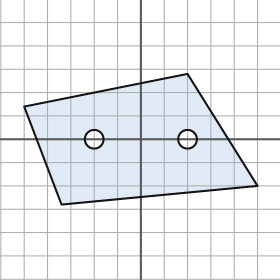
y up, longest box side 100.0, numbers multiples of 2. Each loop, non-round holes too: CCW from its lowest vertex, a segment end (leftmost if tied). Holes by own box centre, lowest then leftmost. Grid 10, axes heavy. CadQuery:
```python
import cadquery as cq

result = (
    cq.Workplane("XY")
    .moveTo(-34.0, -28.0)
    .lineTo(50.0, -20.0)
    .lineTo(20.0, 28.0)
    .lineTo(-50.0, 14.0)
    .close()
    .moveTo(-20.0, 0.0)
    .circle(4.0)
    .moveTo(20.0, 0.0)
    .circle(4.0)
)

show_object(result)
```